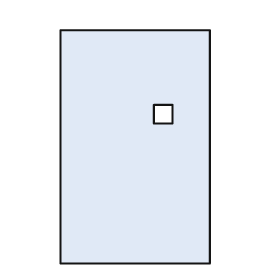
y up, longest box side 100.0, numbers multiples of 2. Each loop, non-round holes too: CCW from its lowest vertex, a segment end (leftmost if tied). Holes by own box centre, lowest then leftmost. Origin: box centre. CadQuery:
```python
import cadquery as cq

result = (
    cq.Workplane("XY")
    .moveTo(-32.0, -50.0)
    .lineTo(32.0, -50.0)
    .lineTo(32.0, 50.0)
    .lineTo(-32.0, 50.0)
    .close()
    .moveTo(8.0, 10.0)
    .lineTo(16.0, 10.0)
    .lineTo(16.0, 18.0)
    .lineTo(8.0, 18.0)
    .close()
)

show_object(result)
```